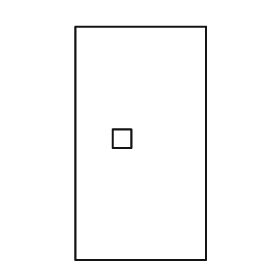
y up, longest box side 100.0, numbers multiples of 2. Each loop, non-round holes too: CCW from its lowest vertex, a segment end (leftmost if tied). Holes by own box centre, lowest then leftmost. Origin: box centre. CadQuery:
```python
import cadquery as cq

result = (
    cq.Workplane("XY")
    .moveTo(-28.0, -50.0)
    .lineTo(28.0, -50.0)
    .lineTo(28.0, 50.0)
    .lineTo(-28.0, 50.0)
    .close()
    .moveTo(-12.0, -2.0)
    .lineTo(-4.0, -2.0)
    .lineTo(-4.0, 6.0)
    .lineTo(-12.0, 6.0)
    .close()
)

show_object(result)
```